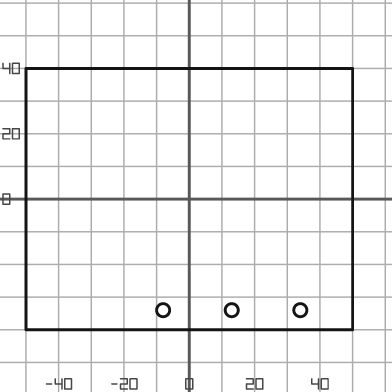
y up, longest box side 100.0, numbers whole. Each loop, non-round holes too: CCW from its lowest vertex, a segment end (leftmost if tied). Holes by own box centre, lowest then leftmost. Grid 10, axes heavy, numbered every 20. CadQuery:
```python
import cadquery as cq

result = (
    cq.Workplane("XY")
    .moveTo(-50.0, -40.0)
    .lineTo(50.0, -40.0)
    .lineTo(50.0, 40.0)
    .lineTo(-50.0, 40.0)
    .close()
    .moveTo(-8.0, -34.0)
    .circle(2.0)
    .moveTo(13.0, -34.0)
    .circle(2.0)
    .moveTo(34.0, -34.0)
    .circle(2.0)
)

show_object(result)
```